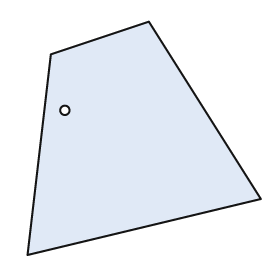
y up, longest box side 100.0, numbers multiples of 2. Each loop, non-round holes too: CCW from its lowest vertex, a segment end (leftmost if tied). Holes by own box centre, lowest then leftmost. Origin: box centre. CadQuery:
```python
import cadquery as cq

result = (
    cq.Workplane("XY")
    .moveTo(-50.0, -50.0)
    .lineTo(50.0, -26.0)
    .lineTo(2.0, 50.0)
    .lineTo(-40.0, 36.0)
    .close()
    .moveTo(-34.0, 12.0)
    .circle(2.0)
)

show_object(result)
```